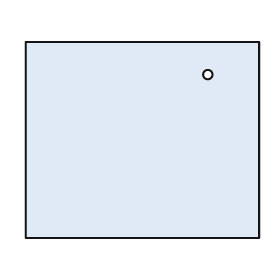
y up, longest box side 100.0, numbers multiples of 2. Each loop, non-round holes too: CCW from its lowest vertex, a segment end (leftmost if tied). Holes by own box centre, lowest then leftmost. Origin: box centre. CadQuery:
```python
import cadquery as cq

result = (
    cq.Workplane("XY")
    .moveTo(-50.0, -42.0)
    .lineTo(50.0, -42.0)
    .lineTo(50.0, 42.0)
    .lineTo(-50.0, 42.0)
    .close()
    .moveTo(28.0, 28.0)
    .circle(2.0)
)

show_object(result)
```